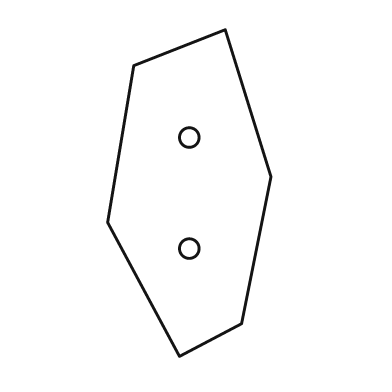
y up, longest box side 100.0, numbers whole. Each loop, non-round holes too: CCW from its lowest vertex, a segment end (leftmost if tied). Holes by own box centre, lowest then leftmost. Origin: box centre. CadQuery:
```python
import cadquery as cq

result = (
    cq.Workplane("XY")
    .moveTo(-3.0, -50.0)
    .lineTo(16.0, -40.0)
    .lineTo(25.0, 5.0)
    .lineTo(11.0, 50.0)
    .lineTo(-17.0, 39.0)
    .lineTo(-25.0, -9.0)
    .close()
    .moveTo(0.0, -17.0)
    .circle(3.0)
    .moveTo(0.0, 17.0)
    .circle(3.0)
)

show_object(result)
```